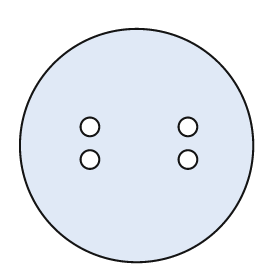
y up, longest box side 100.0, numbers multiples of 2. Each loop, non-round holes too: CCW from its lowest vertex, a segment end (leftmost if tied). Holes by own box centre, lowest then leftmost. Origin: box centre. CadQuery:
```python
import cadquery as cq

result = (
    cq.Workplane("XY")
    .moveTo(0.0, 0.0)
    .circle(50.0)
    .moveTo(-20.0, -6.0)
    .circle(4.0)
    .moveTo(22.0, -6.0)
    .circle(4.0)
    .moveTo(-20.0, 8.0)
    .circle(4.0)
    .moveTo(22.0, 8.0)
    .circle(4.0)
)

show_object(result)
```